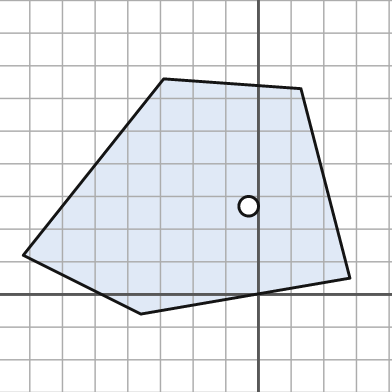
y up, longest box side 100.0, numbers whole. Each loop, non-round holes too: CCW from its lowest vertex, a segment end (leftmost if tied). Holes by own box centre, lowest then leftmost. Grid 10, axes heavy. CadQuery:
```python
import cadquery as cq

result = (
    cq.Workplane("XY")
    .moveTo(-36.0, -6.0)
    .lineTo(28.0, 5.0)
    .lineTo(13.0, 63.0)
    .lineTo(-29.0, 66.0)
    .lineTo(-72.0, 12.0)
    .close()
    .moveTo(-3.0, 27.0)
    .circle(3.0)
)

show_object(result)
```